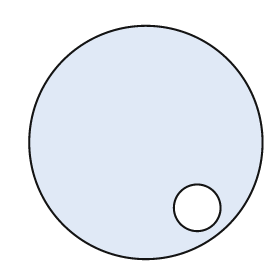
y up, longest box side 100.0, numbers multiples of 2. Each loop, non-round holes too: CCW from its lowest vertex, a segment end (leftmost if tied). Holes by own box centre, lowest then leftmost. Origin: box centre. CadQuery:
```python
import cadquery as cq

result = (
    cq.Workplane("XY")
    .moveTo(0.0, 0.0)
    .circle(50.0)
    .moveTo(22.0, -28.0)
    .circle(10.0)
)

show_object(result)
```